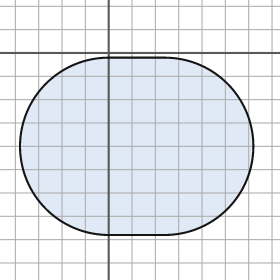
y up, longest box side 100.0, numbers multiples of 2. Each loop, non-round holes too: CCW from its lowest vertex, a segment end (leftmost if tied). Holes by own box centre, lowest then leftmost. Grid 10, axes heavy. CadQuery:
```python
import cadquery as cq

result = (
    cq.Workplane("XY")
    .moveTo(0.0, -78.0)
    .lineTo(24.0, -78.0)
    .threePointArc((62.0, -40.0), (24.0, -2.0))
    .lineTo(0.0, -2.0)
    .threePointArc((-38.0, -40.0), (0.0, -78.0))
    .close()
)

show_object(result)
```